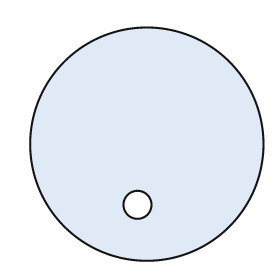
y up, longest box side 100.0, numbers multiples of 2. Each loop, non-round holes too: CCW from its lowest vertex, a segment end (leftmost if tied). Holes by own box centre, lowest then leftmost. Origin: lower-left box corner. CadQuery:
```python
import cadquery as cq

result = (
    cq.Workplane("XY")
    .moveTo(50.0, 50.0)
    .circle(50.0)
    .moveTo(46.0, 24.0)
    .circle(6.0)
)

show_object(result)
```